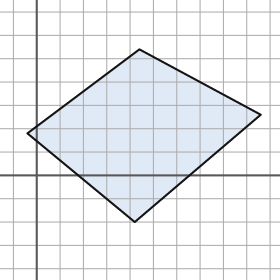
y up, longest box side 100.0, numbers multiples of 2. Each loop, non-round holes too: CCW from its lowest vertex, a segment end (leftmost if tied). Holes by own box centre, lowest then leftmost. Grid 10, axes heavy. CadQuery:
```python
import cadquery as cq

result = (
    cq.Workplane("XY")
    .moveTo(42.0, -20.0)
    .lineTo(96.0, 26.0)
    .lineTo(44.0, 54.0)
    .lineTo(-4.0, 18.0)
    .close()
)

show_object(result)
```